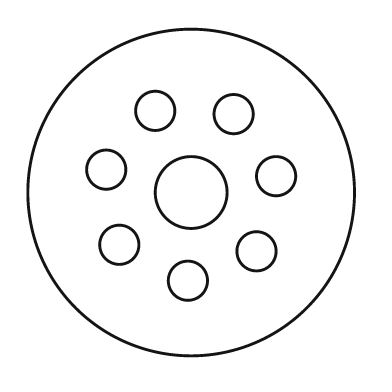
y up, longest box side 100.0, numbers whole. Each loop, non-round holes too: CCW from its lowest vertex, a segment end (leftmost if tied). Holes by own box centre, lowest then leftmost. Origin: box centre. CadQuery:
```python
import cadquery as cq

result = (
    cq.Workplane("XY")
    .moveTo(0.0, 0.0)
    .circle(50.0)
    .moveTo(-1.0, -27.0)
    .circle(6.0)
    .moveTo(20.0, -18.0)
    .circle(6.0)
    .moveTo(-22.0, -16.0)
    .circle(6.0)
    .moveTo(0.0, 0.0)
    .circle(11.0)
    .moveTo(26.0, 5.0)
    .circle(6.0)
    .moveTo(-26.0, 7.0)
    .circle(6.0)
    .moveTo(13.0, 24.0)
    .circle(6.0)
    .moveTo(-11.0, 25.0)
    .circle(6.0)
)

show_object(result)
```